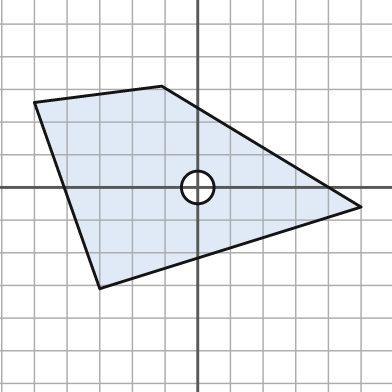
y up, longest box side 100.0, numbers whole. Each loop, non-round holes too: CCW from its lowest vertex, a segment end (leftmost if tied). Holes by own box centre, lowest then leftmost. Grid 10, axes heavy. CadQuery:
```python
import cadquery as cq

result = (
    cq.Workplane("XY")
    .moveTo(-30.0, -31.0)
    .lineTo(50.0, -6.0)
    .lineTo(-11.0, 31.0)
    .lineTo(-50.0, 26.0)
    .close()
    .moveTo(0.0, 0.0)
    .circle(5.0)
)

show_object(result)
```